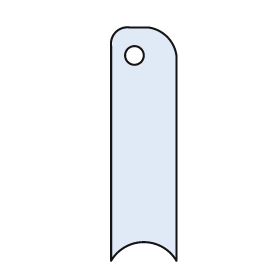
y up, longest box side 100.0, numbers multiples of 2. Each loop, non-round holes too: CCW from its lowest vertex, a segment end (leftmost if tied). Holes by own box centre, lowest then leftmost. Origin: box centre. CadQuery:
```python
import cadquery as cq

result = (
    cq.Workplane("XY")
    .moveTo(-14.0, -50.0)
    .threePointArc((0.0, -42.0), (14.0, -50.0))
    .lineTo(14.0, 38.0)
    .threePointArc((10.0, 46.0), (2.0, 50.0))
    .lineTo(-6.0, 50.0)
    .threePointArc((-12.0, 48.0), (-14.0, 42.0))
    .close()
    .moveTo(-4.0, 38.0)
    .circle(4.0)
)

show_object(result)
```